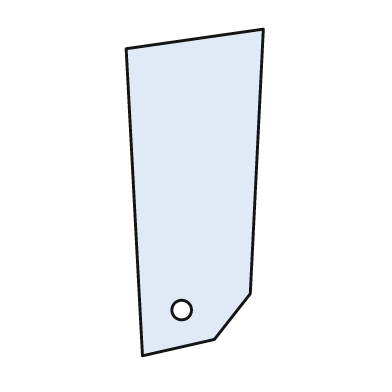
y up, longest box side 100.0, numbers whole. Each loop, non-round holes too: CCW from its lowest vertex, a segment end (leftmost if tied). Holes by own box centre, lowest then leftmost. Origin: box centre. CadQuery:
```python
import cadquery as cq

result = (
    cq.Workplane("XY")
    .moveTo(-16.0, -50.0)
    .lineTo(6.0, -45.0)
    .lineTo(17.0, -31.0)
    .lineTo(21.0, 50.0)
    .lineTo(-21.0, 44.0)
    .close()
    .moveTo(-4.0, -36.0)
    .circle(3.0)
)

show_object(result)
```